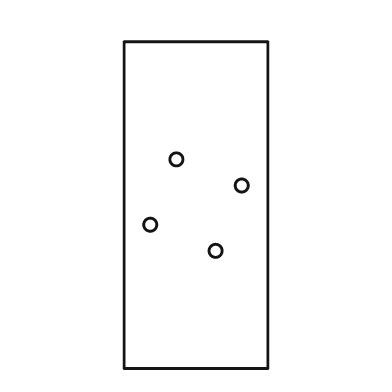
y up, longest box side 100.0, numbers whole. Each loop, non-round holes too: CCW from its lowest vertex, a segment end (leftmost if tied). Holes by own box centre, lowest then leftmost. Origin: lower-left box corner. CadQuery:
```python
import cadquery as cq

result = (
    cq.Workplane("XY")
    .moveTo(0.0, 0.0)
    .lineTo(44.0, 0.0)
    .lineTo(44.0, 100.0)
    .lineTo(0.0, 100.0)
    .close()
    .moveTo(28.0, 36.0)
    .circle(2.0)
    .moveTo(8.0, 44.0)
    .circle(2.0)
    .moveTo(36.0, 56.0)
    .circle(2.0)
    .moveTo(16.0, 64.0)
    .circle(2.0)
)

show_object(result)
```